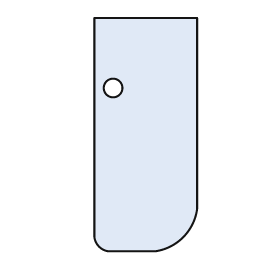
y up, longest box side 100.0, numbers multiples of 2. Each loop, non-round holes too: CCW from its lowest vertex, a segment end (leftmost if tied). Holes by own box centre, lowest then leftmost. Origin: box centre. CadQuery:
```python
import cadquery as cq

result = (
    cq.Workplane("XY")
    .moveTo(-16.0, -50.0)
    .lineTo(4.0, -50.0)
    .threePointArc((16.0, -44.0), (22.0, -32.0))
    .lineTo(22.0, 50.0)
    .lineTo(-22.0, 50.0)
    .lineTo(-22.0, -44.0)
    .threePointArc((-20.0, -48.0), (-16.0, -50.0))
    .close()
    .moveTo(-14.0, 20.0)
    .circle(4.0)
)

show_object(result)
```